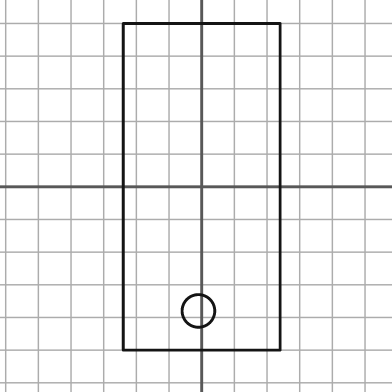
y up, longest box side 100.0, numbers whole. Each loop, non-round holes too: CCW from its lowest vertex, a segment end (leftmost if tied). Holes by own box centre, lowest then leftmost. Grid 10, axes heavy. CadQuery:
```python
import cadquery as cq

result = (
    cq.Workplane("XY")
    .moveTo(-24.0, -50.0)
    .lineTo(24.0, -50.0)
    .lineTo(24.0, 50.0)
    .lineTo(-24.0, 50.0)
    .close()
    .moveTo(-1.0, -38.0)
    .circle(5.0)
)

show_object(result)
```